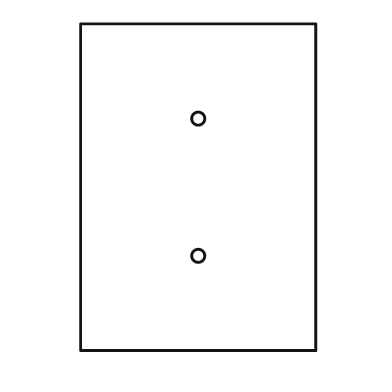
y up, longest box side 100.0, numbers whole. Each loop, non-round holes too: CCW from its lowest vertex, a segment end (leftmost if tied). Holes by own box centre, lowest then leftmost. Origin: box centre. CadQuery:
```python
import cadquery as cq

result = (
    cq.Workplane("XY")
    .moveTo(-36.0, -50.0)
    .lineTo(36.0, -50.0)
    .lineTo(36.0, 50.0)
    .lineTo(-36.0, 50.0)
    .close()
    .moveTo(0.0, -21.0)
    .circle(2.0)
    .moveTo(0.0, 21.0)
    .circle(2.0)
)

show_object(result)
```